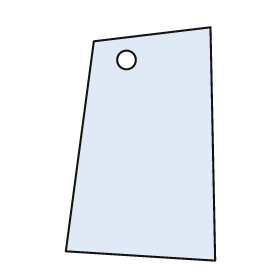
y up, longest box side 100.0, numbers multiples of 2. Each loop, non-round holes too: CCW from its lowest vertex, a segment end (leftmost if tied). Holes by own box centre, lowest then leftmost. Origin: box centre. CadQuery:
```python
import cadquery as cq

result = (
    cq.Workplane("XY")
    .moveTo(32.0, -50.0)
    .lineTo(30.0, 50.0)
    .lineTo(-20.0, 44.0)
    .lineTo(-32.0, -46.0)
    .close()
    .moveTo(-6.0, 36.0)
    .circle(4.0)
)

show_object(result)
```